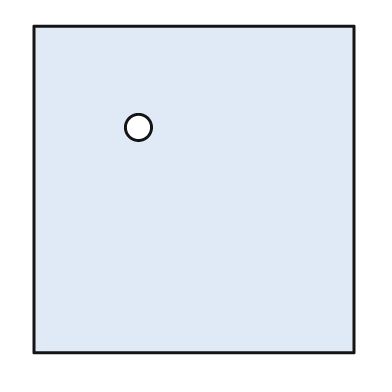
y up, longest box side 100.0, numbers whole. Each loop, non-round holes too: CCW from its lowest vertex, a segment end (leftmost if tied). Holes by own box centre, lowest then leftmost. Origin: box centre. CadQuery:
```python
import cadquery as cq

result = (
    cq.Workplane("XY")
    .moveTo(-49.0, -50.0)
    .lineTo(49.0, -50.0)
    .lineTo(49.0, 50.0)
    .lineTo(-49.0, 50.0)
    .close()
    .moveTo(-17.0, 19.0)
    .circle(4.0)
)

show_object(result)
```